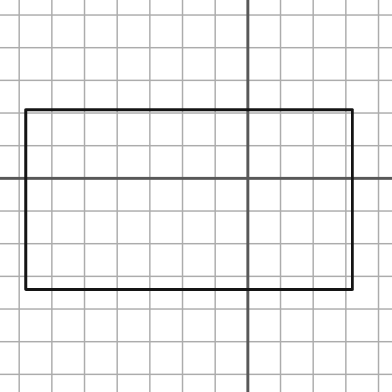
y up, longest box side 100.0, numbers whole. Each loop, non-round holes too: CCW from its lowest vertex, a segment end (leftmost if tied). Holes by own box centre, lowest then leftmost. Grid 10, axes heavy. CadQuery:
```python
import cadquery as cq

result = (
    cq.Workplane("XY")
    .moveTo(-68.0, -34.0)
    .lineTo(32.0, -34.0)
    .lineTo(32.0, 21.0)
    .lineTo(-68.0, 21.0)
    .close()
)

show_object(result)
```